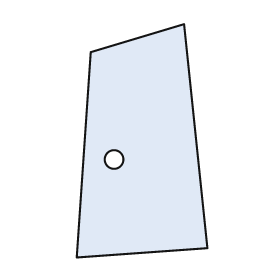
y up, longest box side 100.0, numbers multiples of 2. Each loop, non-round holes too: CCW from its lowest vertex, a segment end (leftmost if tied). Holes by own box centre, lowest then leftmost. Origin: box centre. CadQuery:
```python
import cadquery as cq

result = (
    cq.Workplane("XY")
    .moveTo(-28.0, -50.0)
    .lineTo(28.0, -46.0)
    .lineTo(18.0, 50.0)
    .lineTo(-22.0, 38.0)
    .close()
    .moveTo(-12.0, -8.0)
    .circle(4.0)
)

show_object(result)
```